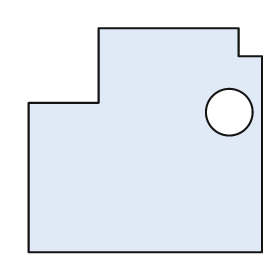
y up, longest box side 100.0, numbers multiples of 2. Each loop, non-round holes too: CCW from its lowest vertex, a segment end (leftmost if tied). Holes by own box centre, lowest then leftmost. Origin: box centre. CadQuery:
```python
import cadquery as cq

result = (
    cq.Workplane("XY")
    .moveTo(-50.0, -48.0)
    .lineTo(50.0, -48.0)
    .lineTo(50.0, 36.0)
    .lineTo(40.0, 36.0)
    .lineTo(40.0, 48.0)
    .lineTo(-20.0, 48.0)
    .lineTo(-20.0, 16.0)
    .lineTo(-50.0, 16.0)
    .close()
    .moveTo(36.0, 12.0)
    .circle(10.0)
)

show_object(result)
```